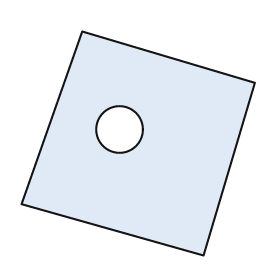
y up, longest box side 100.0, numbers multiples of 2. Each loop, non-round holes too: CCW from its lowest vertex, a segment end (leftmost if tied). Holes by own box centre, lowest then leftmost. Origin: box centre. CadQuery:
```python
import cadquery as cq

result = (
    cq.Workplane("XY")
    .moveTo(28.0, -48.0)
    .lineTo(50.0, 26.0)
    .lineTo(-24.0, 48.0)
    .lineTo(-50.0, -26.0)
    .close()
    .moveTo(-8.0, 6.0)
    .circle(10.0)
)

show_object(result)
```